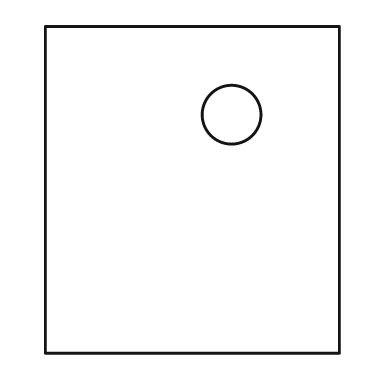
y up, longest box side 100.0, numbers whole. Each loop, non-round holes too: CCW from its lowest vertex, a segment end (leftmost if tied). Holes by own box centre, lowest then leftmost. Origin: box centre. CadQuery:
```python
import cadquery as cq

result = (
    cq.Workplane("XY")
    .moveTo(-45.0, -50.0)
    .lineTo(45.0, -50.0)
    .lineTo(45.0, 50.0)
    .lineTo(-45.0, 50.0)
    .close()
    .moveTo(12.0, 23.0)
    .circle(9.0)
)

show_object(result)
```